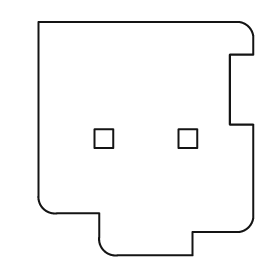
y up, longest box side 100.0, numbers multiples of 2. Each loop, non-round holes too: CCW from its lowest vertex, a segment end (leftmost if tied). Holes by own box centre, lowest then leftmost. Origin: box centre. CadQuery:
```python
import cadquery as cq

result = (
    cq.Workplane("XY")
    .moveTo(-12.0, -50.0)
    .lineTo(20.0, -50.0)
    .lineTo(20.0, -40.0)
    .lineTo(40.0, -40.0)
    .threePointArc((44.0, -38.0), (46.0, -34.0))
    .lineTo(46.0, 6.0)
    .lineTo(36.0, 6.0)
    .lineTo(36.0, 36.0)
    .lineTo(46.0, 36.0)
    .lineTo(46.0, 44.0)
    .threePointArc((44.0, 48.0), (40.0, 50.0))
    .lineTo(-46.0, 50.0)
    .lineTo(-46.0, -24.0)
    .threePointArc((-44.0, -30.0), (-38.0, -32.0))
    .lineTo(-20.0, -32.0)
    .lineTo(-20.0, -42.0)
    .threePointArc((-18.0, -48.0), (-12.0, -50.0))
    .close()
    .moveTo(-22.0, -4.0)
    .lineTo(-14.0, -4.0)
    .lineTo(-14.0, 4.0)
    .lineTo(-22.0, 4.0)
    .close()
    .moveTo(14.0, -4.0)
    .lineTo(22.0, -4.0)
    .lineTo(22.0, 4.0)
    .lineTo(14.0, 4.0)
    .close()
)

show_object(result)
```